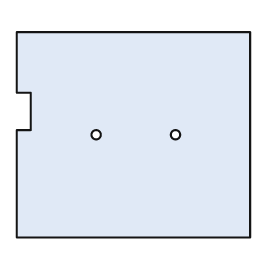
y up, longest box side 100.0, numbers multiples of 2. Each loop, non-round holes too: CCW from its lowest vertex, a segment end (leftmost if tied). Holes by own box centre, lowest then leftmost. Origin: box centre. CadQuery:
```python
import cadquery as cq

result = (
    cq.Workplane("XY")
    .moveTo(-50.0, -44.0)
    .lineTo(50.0, -44.0)
    .lineTo(50.0, 44.0)
    .lineTo(-50.0, 44.0)
    .lineTo(-50.0, 18.0)
    .lineTo(-44.0, 18.0)
    .lineTo(-44.0, 2.0)
    .lineTo(-50.0, 2.0)
    .close()
    .moveTo(-16.0, 0.0)
    .circle(2.0)
    .moveTo(18.0, 0.0)
    .circle(2.0)
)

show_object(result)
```